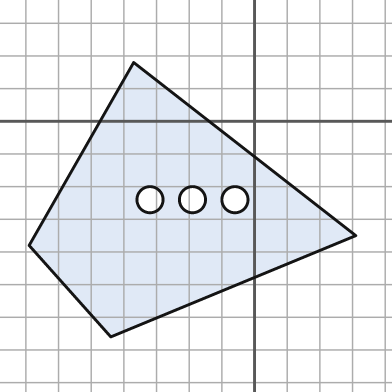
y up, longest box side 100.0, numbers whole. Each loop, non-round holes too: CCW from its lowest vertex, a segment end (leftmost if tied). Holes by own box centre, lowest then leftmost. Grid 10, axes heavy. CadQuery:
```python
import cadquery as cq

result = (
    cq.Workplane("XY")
    .moveTo(-44.0, -66.0)
    .lineTo(31.0, -35.0)
    .lineTo(-37.0, 18.0)
    .lineTo(-69.0, -38.0)
    .close()
    .moveTo(-32.0, -24.0)
    .circle(4.0)
    .moveTo(-19.0, -24.0)
    .circle(4.0)
    .moveTo(-6.0, -24.0)
    .circle(4.0)
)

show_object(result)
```